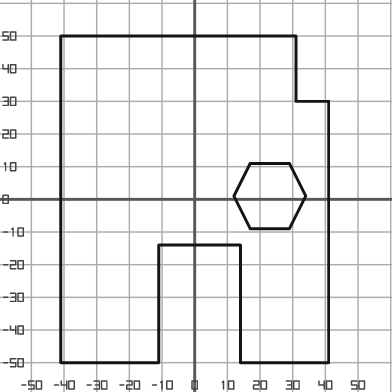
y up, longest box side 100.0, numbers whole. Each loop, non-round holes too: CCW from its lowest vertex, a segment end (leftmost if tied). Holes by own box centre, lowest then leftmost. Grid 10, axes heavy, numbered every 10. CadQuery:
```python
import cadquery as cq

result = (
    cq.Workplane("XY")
    .moveTo(-41.0, -50.0)
    .lineTo(-11.0, -50.0)
    .lineTo(-11.0, -14.0)
    .lineTo(14.0, -14.0)
    .lineTo(14.0, -50.0)
    .lineTo(41.0, -50.0)
    .lineTo(41.0, 30.0)
    .lineTo(31.0, 30.0)
    .lineTo(31.0, 50.0)
    .lineTo(-41.0, 50.0)
    .close()
    .moveTo(17.0, -9.0)
    .lineTo(29.0, -9.0)
    .lineTo(34.0, 1.0)
    .lineTo(29.0, 11.0)
    .lineTo(17.0, 11.0)
    .lineTo(12.0, 1.0)
    .close()
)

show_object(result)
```